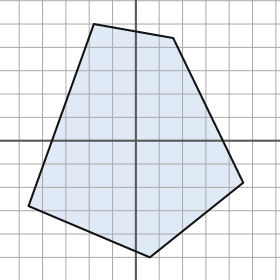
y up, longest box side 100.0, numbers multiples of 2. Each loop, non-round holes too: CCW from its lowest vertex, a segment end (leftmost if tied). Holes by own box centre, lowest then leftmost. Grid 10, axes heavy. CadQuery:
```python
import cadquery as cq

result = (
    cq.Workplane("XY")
    .moveTo(6.0, -50.0)
    .lineTo(46.0, -18.0)
    .lineTo(16.0, 44.0)
    .lineTo(-18.0, 50.0)
    .lineTo(-46.0, -28.0)
    .close()
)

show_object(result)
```